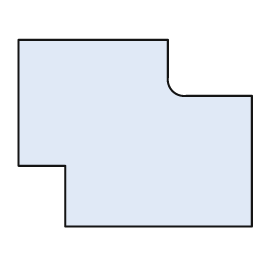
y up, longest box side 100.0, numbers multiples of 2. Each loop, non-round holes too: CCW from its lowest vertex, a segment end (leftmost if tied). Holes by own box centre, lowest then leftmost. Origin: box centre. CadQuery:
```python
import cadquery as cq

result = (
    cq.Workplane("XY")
    .moveTo(-30.0, -40.0)
    .lineTo(50.0, -40.0)
    .lineTo(50.0, 16.0)
    .lineTo(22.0, 16.0)
    .threePointArc((16.0, 18.0), (14.0, 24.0))
    .lineTo(14.0, 40.0)
    .lineTo(-50.0, 40.0)
    .lineTo(-50.0, -14.0)
    .lineTo(-30.0, -14.0)
    .close()
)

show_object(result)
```